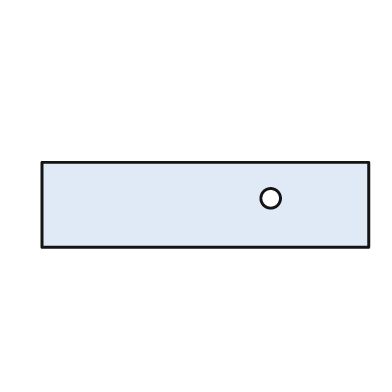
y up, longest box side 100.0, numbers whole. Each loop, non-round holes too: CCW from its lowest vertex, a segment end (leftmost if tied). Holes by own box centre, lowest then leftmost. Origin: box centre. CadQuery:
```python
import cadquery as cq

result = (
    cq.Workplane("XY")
    .moveTo(-50.0, -13.0)
    .lineTo(50.0, -13.0)
    .lineTo(50.0, 13.0)
    .lineTo(-50.0, 13.0)
    .close()
    .moveTo(20.0, 2.0)
    .circle(3.0)
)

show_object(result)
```